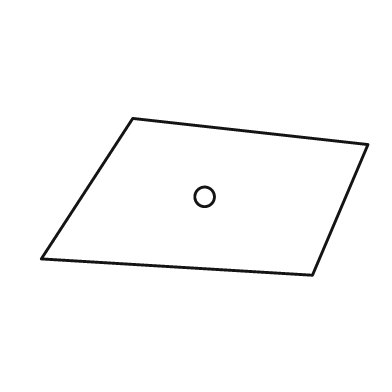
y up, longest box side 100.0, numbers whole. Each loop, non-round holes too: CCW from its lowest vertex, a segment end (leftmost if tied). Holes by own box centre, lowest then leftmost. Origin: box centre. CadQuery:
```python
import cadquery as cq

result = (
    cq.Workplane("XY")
    .moveTo(33.0, -24.0)
    .lineTo(50.0, 16.0)
    .lineTo(-22.0, 24.0)
    .lineTo(-50.0, -19.0)
    .close()
    .moveTo(0.0, 0.0)
    .circle(3.0)
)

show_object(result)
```